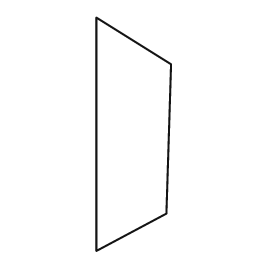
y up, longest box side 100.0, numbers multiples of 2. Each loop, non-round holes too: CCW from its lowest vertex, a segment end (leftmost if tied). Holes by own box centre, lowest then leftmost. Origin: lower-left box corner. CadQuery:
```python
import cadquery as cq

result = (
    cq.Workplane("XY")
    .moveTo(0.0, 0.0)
    .lineTo(30.0, 16.0)
    .lineTo(32.0, 80.0)
    .lineTo(0.0, 100.0)
    .close()
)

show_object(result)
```